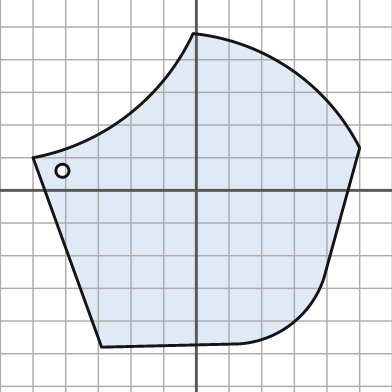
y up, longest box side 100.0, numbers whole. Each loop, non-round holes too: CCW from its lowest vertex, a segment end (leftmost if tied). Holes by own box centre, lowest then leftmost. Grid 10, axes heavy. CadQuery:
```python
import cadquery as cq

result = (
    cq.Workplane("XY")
    .moveTo(-29.0, -48.0)
    .lineTo(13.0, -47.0)
    .threePointArc((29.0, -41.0), (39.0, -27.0))
    .lineTo(50.0, 13.0)
    .threePointArc((29.0, 37.0), (-1.0, 48.0))
    .threePointArc((-21.0, 23.0), (-50.0, 10.0))
    .close()
    .moveTo(-41.0, 6.0)
    .circle(2.0)
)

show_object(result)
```